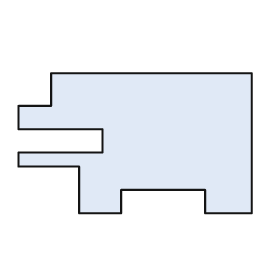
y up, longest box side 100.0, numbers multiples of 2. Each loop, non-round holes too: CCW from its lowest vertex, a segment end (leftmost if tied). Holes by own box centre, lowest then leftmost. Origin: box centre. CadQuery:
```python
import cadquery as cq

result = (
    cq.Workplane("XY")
    .moveTo(-24.0, -30.0)
    .lineTo(-6.0, -30.0)
    .lineTo(-6.0, -20.0)
    .lineTo(30.0, -20.0)
    .lineTo(30.0, -30.0)
    .lineTo(50.0, -30.0)
    .lineTo(50.0, 30.0)
    .lineTo(-36.0, 30.0)
    .lineTo(-36.0, 16.0)
    .lineTo(-50.0, 16.0)
    .lineTo(-50.0, 6.0)
    .lineTo(-14.0, 6.0)
    .lineTo(-14.0, -4.0)
    .lineTo(-50.0, -4.0)
    .lineTo(-50.0, -10.0)
    .lineTo(-24.0, -10.0)
    .close()
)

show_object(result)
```